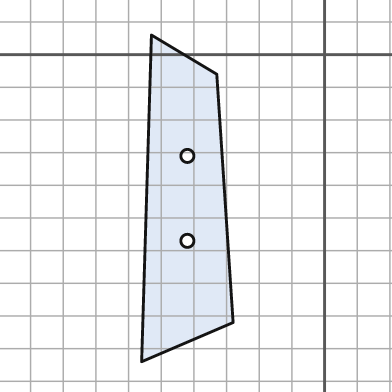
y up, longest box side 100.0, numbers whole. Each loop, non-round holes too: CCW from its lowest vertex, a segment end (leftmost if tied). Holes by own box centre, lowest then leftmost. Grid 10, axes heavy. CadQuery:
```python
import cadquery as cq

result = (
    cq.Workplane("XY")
    .moveTo(-56.0, -94.0)
    .lineTo(-28.0, -82.0)
    .lineTo(-33.0, -6.0)
    .lineTo(-53.0, 6.0)
    .close()
    .moveTo(-42.0, -57.0)
    .circle(2.0)
    .moveTo(-42.0, -31.0)
    .circle(2.0)
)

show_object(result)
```